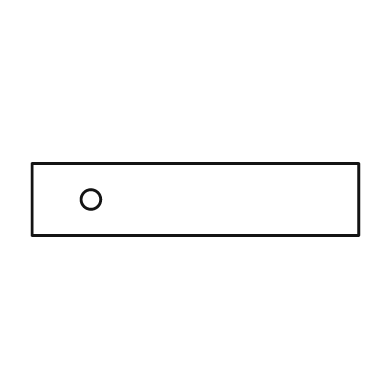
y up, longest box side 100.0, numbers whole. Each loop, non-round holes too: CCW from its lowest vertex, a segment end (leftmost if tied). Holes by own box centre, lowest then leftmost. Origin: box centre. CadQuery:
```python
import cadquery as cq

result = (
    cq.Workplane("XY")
    .moveTo(-50.0, -11.0)
    .lineTo(50.0, -11.0)
    .lineTo(50.0, 11.0)
    .lineTo(-50.0, 11.0)
    .close()
    .moveTo(-32.0, 0.0)
    .circle(3.0)
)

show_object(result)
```